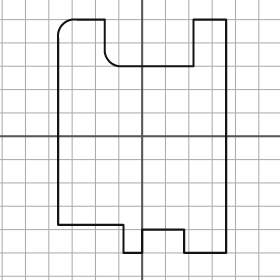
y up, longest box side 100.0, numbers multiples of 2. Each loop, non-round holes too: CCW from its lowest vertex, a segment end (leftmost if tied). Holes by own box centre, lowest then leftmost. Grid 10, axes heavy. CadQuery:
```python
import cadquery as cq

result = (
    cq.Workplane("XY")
    .moveTo(-8.0, -50.0)
    .lineTo(0.0, -50.0)
    .lineTo(0.0, -40.0)
    .lineTo(18.0, -40.0)
    .lineTo(18.0, -50.0)
    .lineTo(36.0, -50.0)
    .lineTo(36.0, 50.0)
    .lineTo(22.0, 50.0)
    .lineTo(22.0, 30.0)
    .lineTo(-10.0, 30.0)
    .threePointArc((-14.0, 32.0), (-16.0, 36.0))
    .lineTo(-16.0, 50.0)
    .lineTo(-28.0, 50.0)
    .threePointArc((-34.0, 48.0), (-36.0, 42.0))
    .lineTo(-36.0, -38.0)
    .lineTo(-8.0, -38.0)
    .close()
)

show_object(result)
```